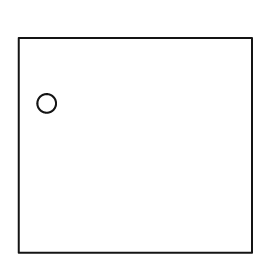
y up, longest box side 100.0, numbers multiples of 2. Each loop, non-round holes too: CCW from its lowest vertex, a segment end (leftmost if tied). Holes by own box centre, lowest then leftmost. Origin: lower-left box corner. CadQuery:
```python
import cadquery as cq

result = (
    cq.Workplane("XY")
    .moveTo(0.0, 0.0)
    .lineTo(100.0, 0.0)
    .lineTo(100.0, 92.0)
    .lineTo(0.0, 92.0)
    .close()
    .moveTo(12.0, 64.0)
    .circle(4.0)
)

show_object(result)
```